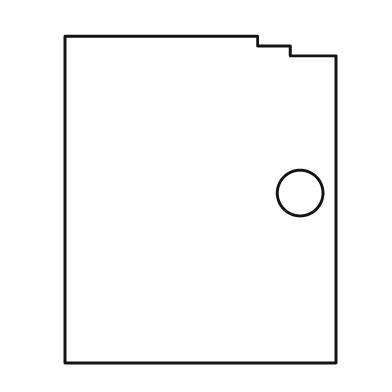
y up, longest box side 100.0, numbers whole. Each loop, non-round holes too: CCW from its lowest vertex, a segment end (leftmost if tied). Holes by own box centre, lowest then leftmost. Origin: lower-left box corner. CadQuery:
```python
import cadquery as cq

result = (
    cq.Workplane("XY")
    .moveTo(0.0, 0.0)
    .lineTo(83.0, 0.0)
    .lineTo(83.0, 94.0)
    .lineTo(69.0, 94.0)
    .lineTo(69.0, 97.0)
    .lineTo(59.0, 97.0)
    .lineTo(59.0, 100.0)
    .lineTo(0.0, 100.0)
    .close()
    .moveTo(72.0, 52.0)
    .circle(7.0)
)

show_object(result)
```